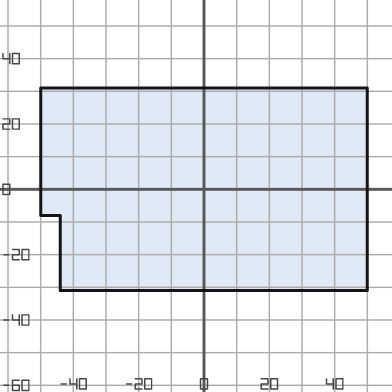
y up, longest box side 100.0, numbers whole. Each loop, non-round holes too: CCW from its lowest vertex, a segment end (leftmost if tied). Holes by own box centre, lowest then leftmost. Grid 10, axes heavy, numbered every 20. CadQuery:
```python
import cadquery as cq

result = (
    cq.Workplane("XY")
    .moveTo(-44.0, -31.0)
    .lineTo(50.0, -31.0)
    .lineTo(50.0, 31.0)
    .lineTo(-50.0, 31.0)
    .lineTo(-50.0, -8.0)
    .lineTo(-44.0, -8.0)
    .close()
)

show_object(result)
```